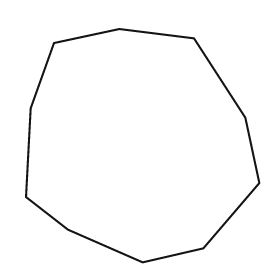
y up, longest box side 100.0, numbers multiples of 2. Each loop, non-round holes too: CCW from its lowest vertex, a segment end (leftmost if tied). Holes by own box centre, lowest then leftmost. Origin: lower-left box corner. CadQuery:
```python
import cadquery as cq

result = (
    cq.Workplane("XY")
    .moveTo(50.0, 0.0)
    .lineTo(76.0, 6.0)
    .lineTo(100.0, 34.0)
    .lineTo(94.0, 62.0)
    .lineTo(72.0, 96.0)
    .lineTo(40.0, 100.0)
    .lineTo(12.0, 94.0)
    .lineTo(2.0, 66.0)
    .lineTo(0.0, 28.0)
    .lineTo(18.0, 14.0)
    .close()
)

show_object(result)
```